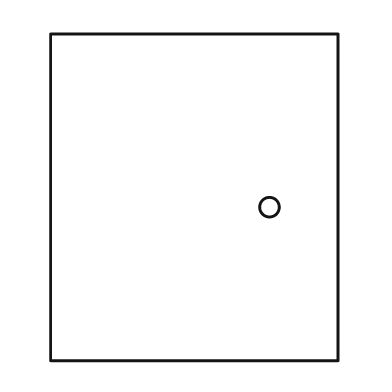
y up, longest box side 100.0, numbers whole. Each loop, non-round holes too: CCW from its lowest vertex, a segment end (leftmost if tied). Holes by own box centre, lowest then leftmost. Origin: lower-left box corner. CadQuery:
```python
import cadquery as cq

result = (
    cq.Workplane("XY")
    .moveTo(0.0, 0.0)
    .lineTo(88.0, 0.0)
    .lineTo(88.0, 100.0)
    .lineTo(0.0, 100.0)
    .close()
    .moveTo(67.0, 47.0)
    .circle(3.0)
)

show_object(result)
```